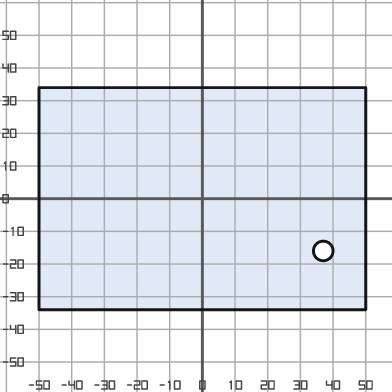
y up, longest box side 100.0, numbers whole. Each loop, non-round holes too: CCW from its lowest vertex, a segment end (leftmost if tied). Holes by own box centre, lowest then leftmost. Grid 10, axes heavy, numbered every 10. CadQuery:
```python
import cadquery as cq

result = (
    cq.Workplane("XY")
    .moveTo(-50.0, -34.0)
    .lineTo(50.0, -34.0)
    .lineTo(50.0, 34.0)
    .lineTo(-50.0, 34.0)
    .close()
    .moveTo(37.0, -16.0)
    .circle(3.0)
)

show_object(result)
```